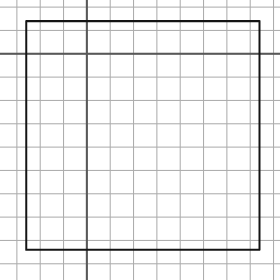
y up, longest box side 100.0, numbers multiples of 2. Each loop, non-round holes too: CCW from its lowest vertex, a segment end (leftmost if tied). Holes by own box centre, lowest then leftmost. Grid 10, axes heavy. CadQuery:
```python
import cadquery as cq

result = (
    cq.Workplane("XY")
    .moveTo(-26.0, -84.0)
    .lineTo(74.0, -84.0)
    .lineTo(74.0, 14.0)
    .lineTo(-26.0, 14.0)
    .close()
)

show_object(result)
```